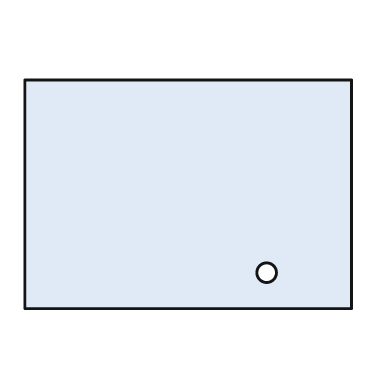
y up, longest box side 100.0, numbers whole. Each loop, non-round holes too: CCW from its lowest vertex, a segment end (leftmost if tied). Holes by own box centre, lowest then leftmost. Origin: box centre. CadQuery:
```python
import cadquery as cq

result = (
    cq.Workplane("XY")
    .moveTo(-50.0, -35.0)
    .lineTo(50.0, -35.0)
    .lineTo(50.0, 35.0)
    .lineTo(-50.0, 35.0)
    .close()
    .moveTo(24.0, -24.0)
    .circle(3.0)
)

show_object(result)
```